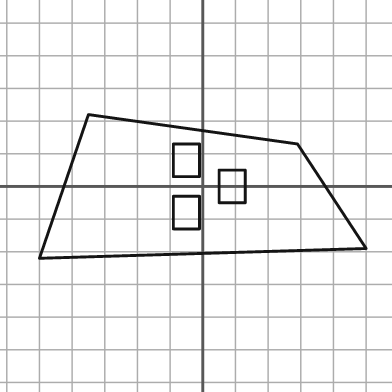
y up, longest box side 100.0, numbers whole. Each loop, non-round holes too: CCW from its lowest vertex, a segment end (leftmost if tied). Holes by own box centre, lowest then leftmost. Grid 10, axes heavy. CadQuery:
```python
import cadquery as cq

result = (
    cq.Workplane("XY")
    .moveTo(-50.0, -22.0)
    .lineTo(50.0, -19.0)
    .lineTo(29.0, 13.0)
    .lineTo(-35.0, 22.0)
    .close()
    .moveTo(-9.0, -13.0)
    .lineTo(-1.0, -13.0)
    .lineTo(-1.0, -3.0)
    .lineTo(-9.0, -3.0)
    .close()
    .moveTo(5.0, -5.0)
    .lineTo(13.0, -5.0)
    .lineTo(13.0, 5.0)
    .lineTo(5.0, 5.0)
    .close()
    .moveTo(-9.0, 3.0)
    .lineTo(-1.0, 3.0)
    .lineTo(-1.0, 13.0)
    .lineTo(-9.0, 13.0)
    .close()
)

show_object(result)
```